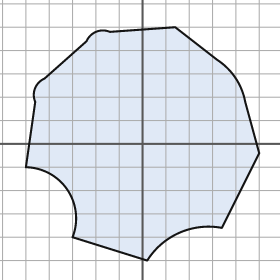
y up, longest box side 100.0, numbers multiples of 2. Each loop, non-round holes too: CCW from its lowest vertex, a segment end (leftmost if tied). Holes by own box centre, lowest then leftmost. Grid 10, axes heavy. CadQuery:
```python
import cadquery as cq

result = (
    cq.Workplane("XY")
    .moveTo(2.0, -50.0)
    .threePointArc((16.0, -38.0), (34.0, -36.0))
    .lineTo(50.0, -4.0)
    .lineTo(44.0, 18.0)
    .threePointArc((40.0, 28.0), (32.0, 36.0))
    .lineTo(14.0, 50.0)
    .lineTo(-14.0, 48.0)
    .threePointArc((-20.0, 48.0), (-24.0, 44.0))
    .lineTo(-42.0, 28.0)
    .threePointArc((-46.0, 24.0), (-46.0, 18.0))
    .lineTo(-50.0, -10.0)
    .threePointArc((-32.0, -20.0), (-30.0, -40.0))
    .close()
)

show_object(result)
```